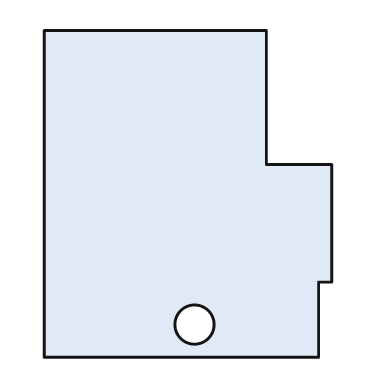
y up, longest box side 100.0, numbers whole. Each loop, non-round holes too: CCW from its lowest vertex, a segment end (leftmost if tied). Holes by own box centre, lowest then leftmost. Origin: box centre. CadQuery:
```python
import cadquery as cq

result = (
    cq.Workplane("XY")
    .moveTo(-44.0, -50.0)
    .lineTo(40.0, -50.0)
    .lineTo(40.0, -27.0)
    .lineTo(44.0, -27.0)
    .lineTo(44.0, 9.0)
    .lineTo(24.0, 9.0)
    .lineTo(24.0, 50.0)
    .lineTo(-44.0, 50.0)
    .close()
    .moveTo(2.0, -40.0)
    .circle(6.0)
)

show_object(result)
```